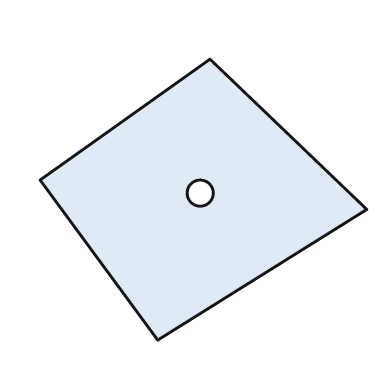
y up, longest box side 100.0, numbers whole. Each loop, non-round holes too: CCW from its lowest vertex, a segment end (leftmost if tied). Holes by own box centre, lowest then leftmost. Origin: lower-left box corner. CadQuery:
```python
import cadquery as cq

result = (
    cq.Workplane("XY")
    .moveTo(36.0, 0.0)
    .lineTo(100.0, 40.0)
    .lineTo(52.0, 86.0)
    .lineTo(0.0, 49.0)
    .close()
    .moveTo(49.0, 45.0)
    .circle(4.0)
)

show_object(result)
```